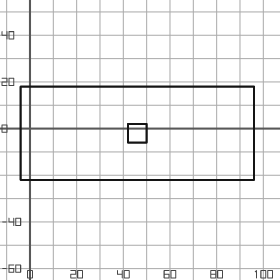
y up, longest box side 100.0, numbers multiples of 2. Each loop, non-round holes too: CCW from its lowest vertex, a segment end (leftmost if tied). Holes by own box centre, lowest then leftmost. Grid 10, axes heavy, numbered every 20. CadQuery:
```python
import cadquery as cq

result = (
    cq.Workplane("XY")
    .moveTo(-4.0, -22.0)
    .lineTo(96.0, -22.0)
    .lineTo(96.0, 18.0)
    .lineTo(-4.0, 18.0)
    .close()
    .moveTo(42.0, -6.0)
    .lineTo(50.0, -6.0)
    .lineTo(50.0, 2.0)
    .lineTo(42.0, 2.0)
    .close()
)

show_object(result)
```